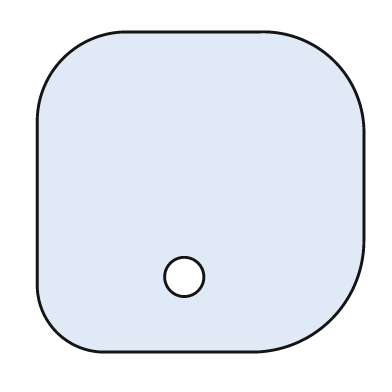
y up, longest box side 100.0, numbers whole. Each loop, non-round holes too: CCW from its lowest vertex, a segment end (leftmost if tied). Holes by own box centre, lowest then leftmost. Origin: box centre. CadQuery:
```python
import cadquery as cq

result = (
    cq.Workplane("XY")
    .moveTo(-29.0, -49.0)
    .lineTo(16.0, -49.0)
    .threePointArc((40.0, -39.0), (50.0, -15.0))
    .lineTo(50.0, 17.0)
    .threePointArc((41.0, 40.0), (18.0, 49.0))
    .lineTo(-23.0, 49.0)
    .threePointArc((-42.0, 41.0), (-50.0, 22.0))
    .lineTo(-50.0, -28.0)
    .threePointArc((-44.0, -43.0), (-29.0, -49.0))
    .close()
    .moveTo(-5.0, -26.0)
    .circle(6.0)
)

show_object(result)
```